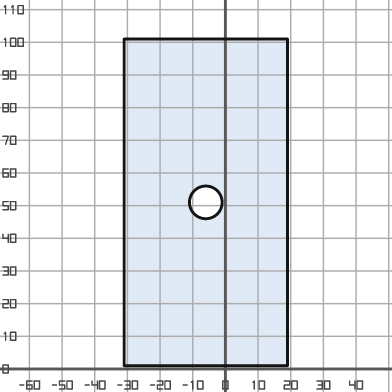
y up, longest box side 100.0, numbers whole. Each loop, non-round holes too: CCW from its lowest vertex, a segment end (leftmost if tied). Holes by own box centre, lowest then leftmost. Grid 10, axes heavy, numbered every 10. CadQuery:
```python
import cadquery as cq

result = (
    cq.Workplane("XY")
    .moveTo(-31.0, 1.0)
    .lineTo(19.0, 1.0)
    .lineTo(19.0, 101.0)
    .lineTo(-31.0, 101.0)
    .close()
    .moveTo(-6.0, 51.0)
    .circle(5.0)
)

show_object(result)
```